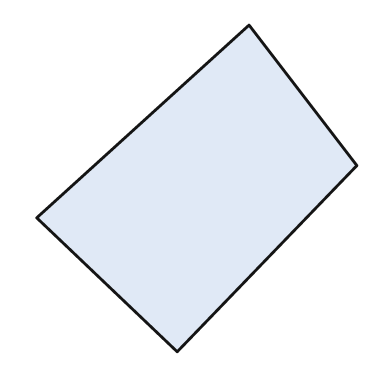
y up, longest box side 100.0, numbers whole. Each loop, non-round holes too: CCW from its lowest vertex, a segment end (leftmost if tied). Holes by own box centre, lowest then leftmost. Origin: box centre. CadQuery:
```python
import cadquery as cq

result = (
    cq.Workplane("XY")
    .moveTo(-6.0, -50.0)
    .lineTo(49.0, 7.0)
    .lineTo(16.0, 50.0)
    .lineTo(-49.0, -9.0)
    .close()
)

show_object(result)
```